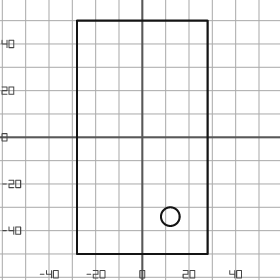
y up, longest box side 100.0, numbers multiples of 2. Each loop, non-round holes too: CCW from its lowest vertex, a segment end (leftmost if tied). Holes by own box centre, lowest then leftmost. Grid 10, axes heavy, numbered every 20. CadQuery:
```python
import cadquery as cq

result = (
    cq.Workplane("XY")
    .moveTo(-28.0, -50.0)
    .lineTo(28.0, -50.0)
    .lineTo(28.0, 50.0)
    .lineTo(-28.0, 50.0)
    .close()
    .moveTo(12.0, -34.0)
    .circle(4.0)
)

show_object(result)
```